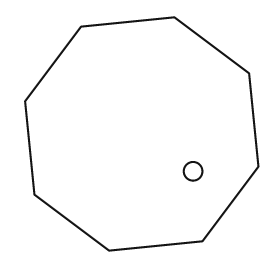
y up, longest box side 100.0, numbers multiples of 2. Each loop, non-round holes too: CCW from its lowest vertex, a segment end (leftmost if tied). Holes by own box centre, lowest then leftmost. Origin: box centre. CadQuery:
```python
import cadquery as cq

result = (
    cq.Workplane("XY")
    .moveTo(-14.0, -50.0)
    .lineTo(26.0, -46.0)
    .lineTo(50.0, -14.0)
    .lineTo(46.0, 26.0)
    .lineTo(14.0, 50.0)
    .lineTo(-26.0, 46.0)
    .lineTo(-50.0, 14.0)
    .lineTo(-46.0, -26.0)
    .close()
    .moveTo(22.0, -16.0)
    .circle(4.0)
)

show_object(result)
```